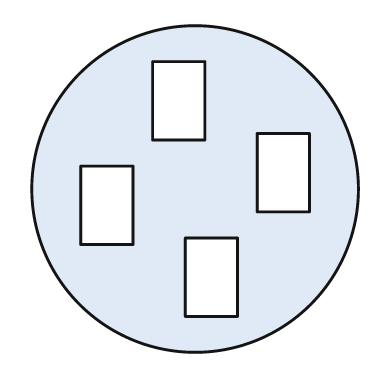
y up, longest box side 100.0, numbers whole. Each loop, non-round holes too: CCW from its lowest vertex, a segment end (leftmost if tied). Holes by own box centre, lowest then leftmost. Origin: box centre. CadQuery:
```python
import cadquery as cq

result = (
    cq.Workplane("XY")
    .moveTo(0.0, 0.0)
    .circle(50.0)
    .moveTo(-3.0, -39.0)
    .lineTo(13.0, -39.0)
    .lineTo(13.0, -15.0)
    .lineTo(-3.0, -15.0)
    .close()
    .moveTo(-35.0, -17.0)
    .lineTo(-19.0, -17.0)
    .lineTo(-19.0, 7.0)
    .lineTo(-35.0, 7.0)
    .close()
    .moveTo(19.0, -7.0)
    .lineTo(35.0, -7.0)
    .lineTo(35.0, 17.0)
    .lineTo(19.0, 17.0)
    .close()
    .moveTo(-13.0, 15.0)
    .lineTo(3.0, 15.0)
    .lineTo(3.0, 39.0)
    .lineTo(-13.0, 39.0)
    .close()
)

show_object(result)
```